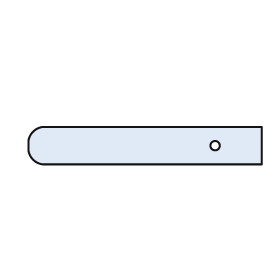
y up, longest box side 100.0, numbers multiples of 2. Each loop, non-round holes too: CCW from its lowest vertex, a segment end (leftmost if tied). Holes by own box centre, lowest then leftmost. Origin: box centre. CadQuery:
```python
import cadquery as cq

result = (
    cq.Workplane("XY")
    .moveTo(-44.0, -8.0)
    .lineTo(50.0, -8.0)
    .lineTo(50.0, 8.0)
    .lineTo(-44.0, 8.0)
    .threePointArc((-48.0, 6.0), (-50.0, 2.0))
    .lineTo(-50.0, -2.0)
    .threePointArc((-48.0, -6.0), (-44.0, -8.0))
    .close()
    .moveTo(30.0, 0.0)
    .circle(2.0)
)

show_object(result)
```